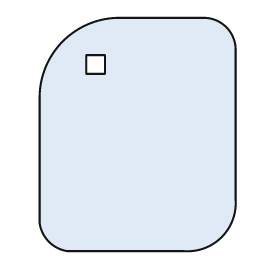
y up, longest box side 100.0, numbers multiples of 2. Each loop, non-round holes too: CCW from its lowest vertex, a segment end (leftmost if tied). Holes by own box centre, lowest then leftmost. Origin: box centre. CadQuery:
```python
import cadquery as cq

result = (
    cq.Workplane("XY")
    .moveTo(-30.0, -50.0)
    .lineTo(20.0, -50.0)
    .threePointArc((36.0, -44.0), (42.0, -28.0))
    .lineTo(42.0, 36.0)
    .threePointArc((38.0, 46.0), (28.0, 50.0))
    .lineTo(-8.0, 50.0)
    .threePointArc((-32.0, 40.0), (-42.0, 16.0))
    .lineTo(-42.0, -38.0)
    .threePointArc((-38.0, -46.0), (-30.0, -50.0))
    .close()
    .moveTo(-22.0, 26.0)
    .lineTo(-14.0, 26.0)
    .lineTo(-14.0, 34.0)
    .lineTo(-22.0, 34.0)
    .close()
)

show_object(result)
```